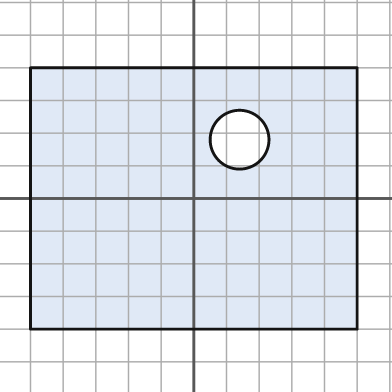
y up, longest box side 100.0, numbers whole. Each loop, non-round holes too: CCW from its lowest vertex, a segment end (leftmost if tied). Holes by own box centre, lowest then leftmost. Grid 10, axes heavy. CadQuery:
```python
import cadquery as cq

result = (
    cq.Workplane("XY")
    .moveTo(-50.0, -40.0)
    .lineTo(50.0, -40.0)
    .lineTo(50.0, 40.0)
    .lineTo(-50.0, 40.0)
    .close()
    .moveTo(14.0, 18.0)
    .circle(9.0)
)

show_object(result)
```